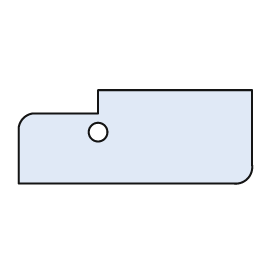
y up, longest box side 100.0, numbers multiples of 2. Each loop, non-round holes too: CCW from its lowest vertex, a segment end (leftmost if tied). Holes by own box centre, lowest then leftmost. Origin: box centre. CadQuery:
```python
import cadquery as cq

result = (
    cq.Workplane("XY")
    .moveTo(-50.0, -20.0)
    .lineTo(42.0, -20.0)
    .threePointArc((48.0, -18.0), (50.0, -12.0))
    .lineTo(50.0, 20.0)
    .lineTo(-16.0, 20.0)
    .lineTo(-16.0, 10.0)
    .lineTo(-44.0, 10.0)
    .threePointArc((-48.0, 8.0), (-50.0, 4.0))
    .close()
    .moveTo(-16.0, 2.0)
    .circle(4.0)
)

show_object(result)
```